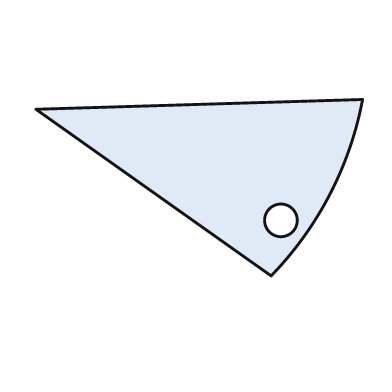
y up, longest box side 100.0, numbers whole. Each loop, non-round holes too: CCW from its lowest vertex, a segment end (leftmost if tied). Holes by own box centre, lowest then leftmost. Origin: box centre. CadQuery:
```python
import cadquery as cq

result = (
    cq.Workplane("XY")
    .moveTo(22.0, -27.0)
    .threePointArc((40.0, -2.0), (50.0, 27.0))
    .lineTo(-50.0, 24.0)
    .close()
    .moveTo(25.0, -10.0)
    .circle(5.0)
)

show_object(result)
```